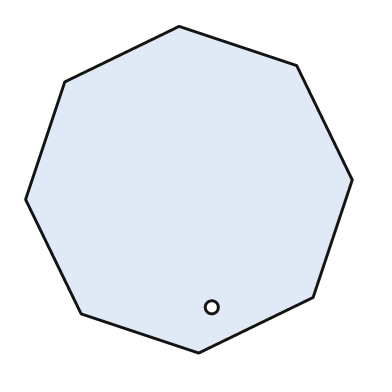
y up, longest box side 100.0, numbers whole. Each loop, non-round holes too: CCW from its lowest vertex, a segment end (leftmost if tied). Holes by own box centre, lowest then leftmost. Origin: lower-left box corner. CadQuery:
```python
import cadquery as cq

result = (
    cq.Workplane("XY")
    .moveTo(53.0, 0.0)
    .lineTo(88.0, 17.0)
    .lineTo(100.0, 53.0)
    .lineTo(83.0, 88.0)
    .lineTo(47.0, 100.0)
    .lineTo(12.0, 83.0)
    .lineTo(0.0, 47.0)
    .lineTo(17.0, 12.0)
    .close()
    .moveTo(57.0, 14.0)
    .circle(2.0)
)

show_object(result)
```